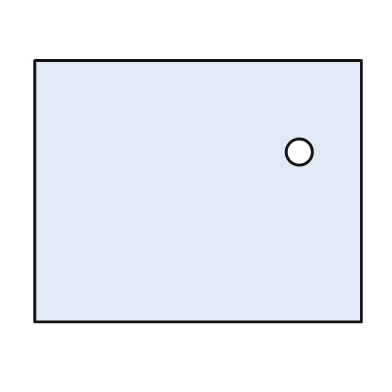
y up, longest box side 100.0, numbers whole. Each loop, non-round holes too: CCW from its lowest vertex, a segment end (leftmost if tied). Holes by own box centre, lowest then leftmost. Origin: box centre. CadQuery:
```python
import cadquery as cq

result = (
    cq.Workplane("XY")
    .moveTo(-50.0, -40.0)
    .lineTo(50.0, -40.0)
    .lineTo(50.0, 40.0)
    .lineTo(-50.0, 40.0)
    .close()
    .moveTo(31.0, 12.0)
    .circle(4.0)
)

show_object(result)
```